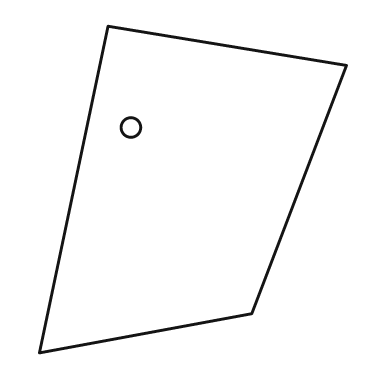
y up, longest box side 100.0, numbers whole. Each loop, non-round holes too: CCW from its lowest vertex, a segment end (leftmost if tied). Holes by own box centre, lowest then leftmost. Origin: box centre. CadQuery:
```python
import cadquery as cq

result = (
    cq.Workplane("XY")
    .moveTo(-47.0, -50.0)
    .lineTo(18.0, -38.0)
    .lineTo(47.0, 38.0)
    .lineTo(-26.0, 50.0)
    .close()
    .moveTo(-19.0, 19.0)
    .circle(3.0)
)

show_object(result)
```